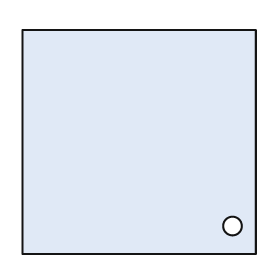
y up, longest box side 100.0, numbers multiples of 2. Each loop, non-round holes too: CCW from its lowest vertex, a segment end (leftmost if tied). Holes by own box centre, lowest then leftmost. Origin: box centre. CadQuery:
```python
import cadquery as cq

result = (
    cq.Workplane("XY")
    .moveTo(-50.0, -48.0)
    .lineTo(50.0, -48.0)
    .lineTo(50.0, 48.0)
    .lineTo(-50.0, 48.0)
    .close()
    .moveTo(40.0, -36.0)
    .circle(4.0)
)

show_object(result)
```